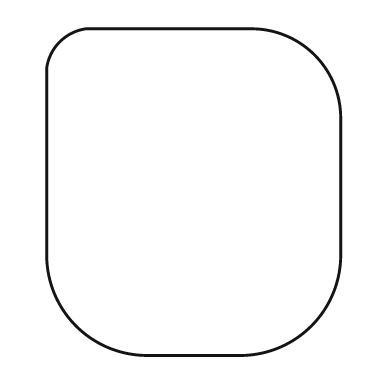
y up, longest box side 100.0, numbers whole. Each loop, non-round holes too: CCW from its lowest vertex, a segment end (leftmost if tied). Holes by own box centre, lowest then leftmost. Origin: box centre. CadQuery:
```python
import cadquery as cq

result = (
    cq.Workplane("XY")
    .moveTo(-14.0, -50.0)
    .lineTo(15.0, -50.0)
    .threePointArc((36.0, -41.0), (45.0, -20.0))
    .lineTo(45.0, 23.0)
    .threePointArc((37.0, 42.0), (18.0, 50.0))
    .lineTo(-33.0, 50.0)
    .threePointArc((-41.0, 46.0), (-45.0, 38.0))
    .lineTo(-45.0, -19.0)
    .threePointArc((-36.0, -41.0), (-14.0, -50.0))
    .close()
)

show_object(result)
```